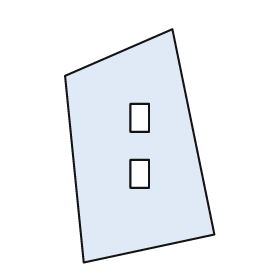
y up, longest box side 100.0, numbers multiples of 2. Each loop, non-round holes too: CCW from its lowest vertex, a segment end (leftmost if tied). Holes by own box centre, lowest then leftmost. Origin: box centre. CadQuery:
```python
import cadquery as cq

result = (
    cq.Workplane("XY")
    .moveTo(-24.0, -50.0)
    .lineTo(32.0, -38.0)
    .lineTo(14.0, 50.0)
    .lineTo(-32.0, 30.0)
    .close()
    .moveTo(-4.0, -18.0)
    .lineTo(4.0, -18.0)
    .lineTo(4.0, -6.0)
    .lineTo(-4.0, -6.0)
    .close()
    .moveTo(-4.0, 6.0)
    .lineTo(4.0, 6.0)
    .lineTo(4.0, 18.0)
    .lineTo(-4.0, 18.0)
    .close()
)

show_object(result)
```